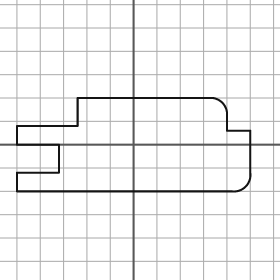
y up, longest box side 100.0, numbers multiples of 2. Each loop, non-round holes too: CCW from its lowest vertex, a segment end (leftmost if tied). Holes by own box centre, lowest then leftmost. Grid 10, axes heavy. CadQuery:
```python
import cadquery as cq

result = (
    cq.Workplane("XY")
    .moveTo(-50.0, -20.0)
    .lineTo(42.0, -20.0)
    .threePointArc((48.0, -18.0), (50.0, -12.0))
    .lineTo(50.0, 6.0)
    .lineTo(40.0, 6.0)
    .lineTo(40.0, 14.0)
    .threePointArc((38.0, 18.0), (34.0, 20.0))
    .lineTo(-24.0, 20.0)
    .lineTo(-24.0, 8.0)
    .lineTo(-50.0, 8.0)
    .lineTo(-50.0, 0.0)
    .lineTo(-32.0, 0.0)
    .lineTo(-32.0, -12.0)
    .lineTo(-50.0, -12.0)
    .close()
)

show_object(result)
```